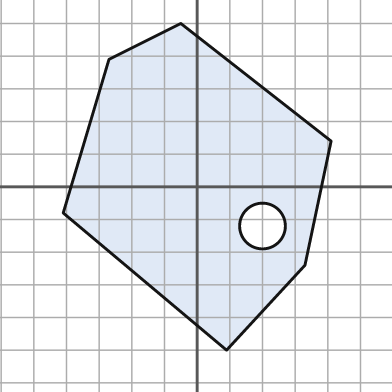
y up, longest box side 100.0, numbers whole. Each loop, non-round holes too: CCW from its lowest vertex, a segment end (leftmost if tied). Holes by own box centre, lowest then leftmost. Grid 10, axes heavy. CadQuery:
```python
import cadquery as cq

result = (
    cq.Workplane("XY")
    .moveTo(9.0, -50.0)
    .lineTo(33.0, -24.0)
    .lineTo(41.0, 14.0)
    .lineTo(-5.0, 50.0)
    .lineTo(-27.0, 39.0)
    .lineTo(-41.0, -8.0)
    .close()
    .moveTo(20.0, -12.0)
    .circle(7.0)
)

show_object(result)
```